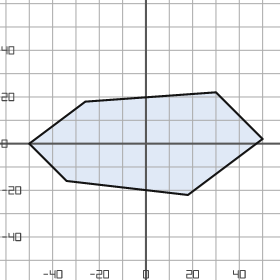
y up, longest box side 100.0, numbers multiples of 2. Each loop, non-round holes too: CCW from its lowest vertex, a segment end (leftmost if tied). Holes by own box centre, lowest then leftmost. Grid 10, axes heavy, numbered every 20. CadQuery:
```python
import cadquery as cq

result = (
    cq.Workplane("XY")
    .moveTo(18.0, -22.0)
    .lineTo(50.0, 2.0)
    .lineTo(30.0, 22.0)
    .lineTo(-26.0, 18.0)
    .lineTo(-50.0, 0.0)
    .lineTo(-34.0, -16.0)
    .close()
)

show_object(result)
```